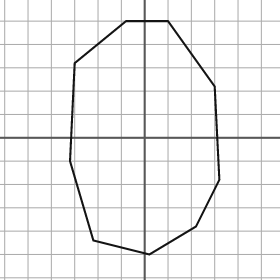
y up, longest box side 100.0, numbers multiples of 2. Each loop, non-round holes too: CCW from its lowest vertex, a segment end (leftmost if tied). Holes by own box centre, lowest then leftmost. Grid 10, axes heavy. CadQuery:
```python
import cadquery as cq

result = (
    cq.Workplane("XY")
    .moveTo(2.0, -50.0)
    .lineTo(22.0, -38.0)
    .lineTo(32.0, -18.0)
    .lineTo(30.0, 22.0)
    .lineTo(10.0, 50.0)
    .lineTo(-8.0, 50.0)
    .lineTo(-30.0, 32.0)
    .lineTo(-32.0, -10.0)
    .lineTo(-22.0, -44.0)
    .close()
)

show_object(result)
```